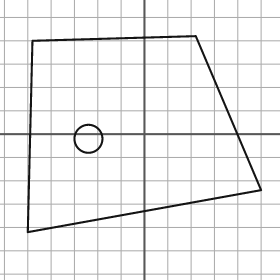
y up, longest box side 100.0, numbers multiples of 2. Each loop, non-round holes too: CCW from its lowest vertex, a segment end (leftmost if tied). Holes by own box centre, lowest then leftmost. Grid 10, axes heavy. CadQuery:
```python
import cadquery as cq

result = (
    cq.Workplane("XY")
    .moveTo(-50.0, -42.0)
    .lineTo(50.0, -24.0)
    .lineTo(22.0, 42.0)
    .lineTo(-48.0, 40.0)
    .close()
    .moveTo(-24.0, -2.0)
    .circle(6.0)
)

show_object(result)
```